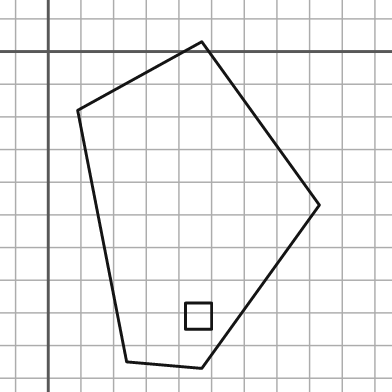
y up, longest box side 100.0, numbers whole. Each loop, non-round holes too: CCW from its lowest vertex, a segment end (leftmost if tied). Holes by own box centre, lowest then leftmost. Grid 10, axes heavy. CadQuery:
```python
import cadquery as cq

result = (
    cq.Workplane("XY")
    .moveTo(47.0, -97.0)
    .lineTo(83.0, -47.0)
    .lineTo(47.0, 3.0)
    .lineTo(9.0, -18.0)
    .lineTo(24.0, -95.0)
    .close()
    .moveTo(42.0, -85.0)
    .lineTo(50.0, -85.0)
    .lineTo(50.0, -77.0)
    .lineTo(42.0, -77.0)
    .close()
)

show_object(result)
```